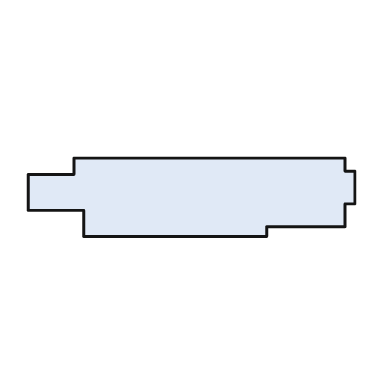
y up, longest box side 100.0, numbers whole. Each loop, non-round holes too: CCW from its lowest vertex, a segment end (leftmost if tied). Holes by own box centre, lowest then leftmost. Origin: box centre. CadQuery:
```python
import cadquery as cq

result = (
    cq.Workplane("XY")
    .moveTo(-33.0, -12.0)
    .lineTo(23.0, -12.0)
    .lineTo(23.0, -9.0)
    .lineTo(47.0, -9.0)
    .lineTo(47.0, -2.0)
    .lineTo(50.0, -2.0)
    .lineTo(50.0, 8.0)
    .lineTo(47.0, 8.0)
    .lineTo(47.0, 12.0)
    .lineTo(-36.0, 12.0)
    .lineTo(-36.0, 7.0)
    .lineTo(-50.0, 7.0)
    .lineTo(-50.0, -4.0)
    .lineTo(-33.0, -4.0)
    .close()
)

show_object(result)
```